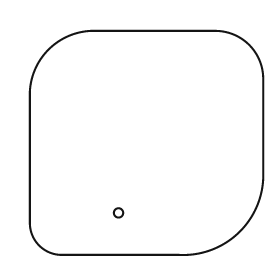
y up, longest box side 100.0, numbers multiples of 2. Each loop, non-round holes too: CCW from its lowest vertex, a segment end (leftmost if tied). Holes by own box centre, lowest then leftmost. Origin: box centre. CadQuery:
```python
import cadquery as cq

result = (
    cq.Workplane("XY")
    .moveTo(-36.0, -48.0)
    .lineTo(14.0, -48.0)
    .threePointArc((40.0, -38.0), (50.0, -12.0))
    .lineTo(50.0, 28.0)
    .threePointArc((44.0, 42.0), (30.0, 48.0))
    .lineTo(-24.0, 48.0)
    .threePointArc((-42.0, 40.0), (-50.0, 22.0))
    .lineTo(-50.0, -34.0)
    .threePointArc((-46.0, -44.0), (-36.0, -48.0))
    .close()
    .moveTo(-12.0, -30.0)
    .circle(2.0)
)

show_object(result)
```